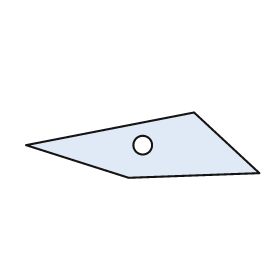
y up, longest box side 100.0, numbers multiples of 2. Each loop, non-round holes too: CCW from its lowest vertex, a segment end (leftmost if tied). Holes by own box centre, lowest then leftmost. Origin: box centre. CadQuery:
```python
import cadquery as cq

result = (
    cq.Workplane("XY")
    .moveTo(-6.0, -14.0)
    .lineTo(50.0, -12.0)
    .lineTo(22.0, 14.0)
    .lineTo(-50.0, 0.0)
    .close()
    .moveTo(0.0, 0.0)
    .circle(4.0)
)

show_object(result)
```